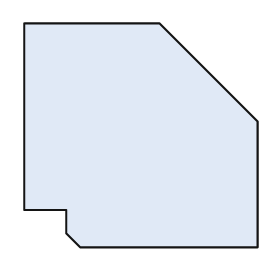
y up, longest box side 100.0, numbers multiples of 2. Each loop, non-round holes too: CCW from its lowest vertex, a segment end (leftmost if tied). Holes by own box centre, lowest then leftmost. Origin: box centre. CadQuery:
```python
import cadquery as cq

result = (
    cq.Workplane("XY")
    .moveTo(-26.0, -48.0)
    .lineTo(50.0, -48.0)
    .lineTo(50.0, 6.0)
    .lineTo(8.0, 48.0)
    .lineTo(-50.0, 48.0)
    .lineTo(-50.0, -32.0)
    .lineTo(-32.0, -32.0)
    .lineTo(-32.0, -42.0)
    .close()
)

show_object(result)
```